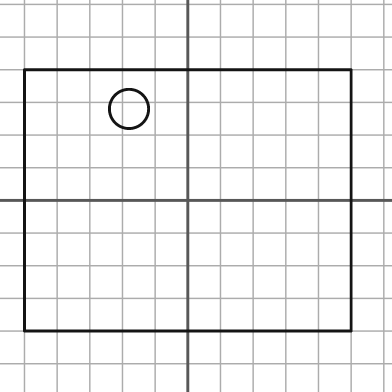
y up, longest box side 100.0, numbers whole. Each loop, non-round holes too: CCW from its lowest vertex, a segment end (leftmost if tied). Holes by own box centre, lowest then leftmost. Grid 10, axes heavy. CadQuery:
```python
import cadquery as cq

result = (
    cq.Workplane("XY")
    .moveTo(-50.0, -40.0)
    .lineTo(50.0, -40.0)
    .lineTo(50.0, 40.0)
    .lineTo(-50.0, 40.0)
    .close()
    .moveTo(-18.0, 28.0)
    .circle(6.0)
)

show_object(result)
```